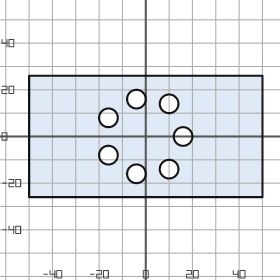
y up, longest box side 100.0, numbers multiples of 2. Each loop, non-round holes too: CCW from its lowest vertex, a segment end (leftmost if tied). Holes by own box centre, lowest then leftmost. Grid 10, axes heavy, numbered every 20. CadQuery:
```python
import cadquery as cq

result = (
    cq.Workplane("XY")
    .moveTo(-50.0, -26.0)
    .lineTo(50.0, -26.0)
    .lineTo(50.0, 26.0)
    .lineTo(-50.0, 26.0)
    .close()
    .moveTo(-4.0, -16.0)
    .circle(4.0)
    .moveTo(10.0, -14.0)
    .circle(4.0)
    .moveTo(-16.0, -8.0)
    .circle(4.0)
    .moveTo(16.0, 0.0)
    .circle(4.0)
    .moveTo(-16.0, 8.0)
    .circle(4.0)
    .moveTo(10.0, 14.0)
    .circle(4.0)
    .moveTo(-4.0, 16.0)
    .circle(4.0)
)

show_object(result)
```